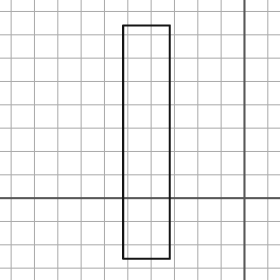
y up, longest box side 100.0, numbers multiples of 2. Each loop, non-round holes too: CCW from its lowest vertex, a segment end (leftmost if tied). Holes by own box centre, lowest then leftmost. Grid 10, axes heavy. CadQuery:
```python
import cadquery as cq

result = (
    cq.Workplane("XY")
    .moveTo(-52.0, -26.0)
    .lineTo(-32.0, -26.0)
    .lineTo(-32.0, 74.0)
    .lineTo(-52.0, 74.0)
    .close()
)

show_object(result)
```